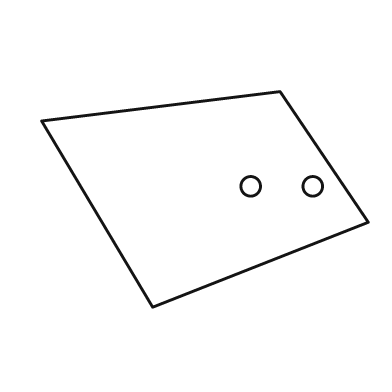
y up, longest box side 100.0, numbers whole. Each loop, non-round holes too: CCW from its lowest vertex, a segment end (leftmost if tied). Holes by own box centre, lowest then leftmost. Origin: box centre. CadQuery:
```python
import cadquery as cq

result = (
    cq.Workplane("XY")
    .moveTo(-16.0, -33.0)
    .lineTo(50.0, -7.0)
    .lineTo(23.0, 33.0)
    .lineTo(-50.0, 24.0)
    .close()
    .moveTo(14.0, 4.0)
    .circle(3.0)
    .moveTo(33.0, 4.0)
    .circle(3.0)
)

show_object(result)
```